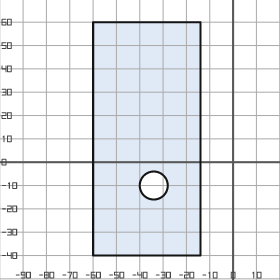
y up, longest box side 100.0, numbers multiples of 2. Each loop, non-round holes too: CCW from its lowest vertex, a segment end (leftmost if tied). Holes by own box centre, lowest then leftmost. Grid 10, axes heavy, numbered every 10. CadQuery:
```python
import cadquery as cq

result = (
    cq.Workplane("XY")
    .moveTo(-60.0, -40.0)
    .lineTo(-14.0, -40.0)
    .lineTo(-14.0, 60.0)
    .lineTo(-60.0, 60.0)
    .close()
    .moveTo(-34.0, -10.0)
    .circle(6.0)
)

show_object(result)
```